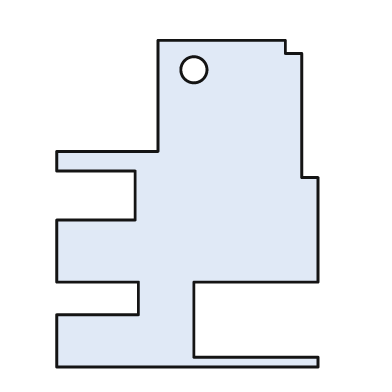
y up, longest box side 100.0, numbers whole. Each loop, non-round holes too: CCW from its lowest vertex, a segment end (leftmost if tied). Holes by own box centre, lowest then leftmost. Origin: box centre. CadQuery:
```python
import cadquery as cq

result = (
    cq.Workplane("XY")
    .moveTo(-40.0, -50.0)
    .lineTo(40.0, -50.0)
    .lineTo(40.0, -47.0)
    .lineTo(2.0, -47.0)
    .lineTo(2.0, -24.0)
    .lineTo(40.0, -24.0)
    .lineTo(40.0, 8.0)
    .lineTo(35.0, 8.0)
    .lineTo(35.0, 46.0)
    .lineTo(30.0, 46.0)
    .lineTo(30.0, 50.0)
    .lineTo(-9.0, 50.0)
    .lineTo(-9.0, 16.0)
    .lineTo(-40.0, 16.0)
    .lineTo(-40.0, 10.0)
    .lineTo(-16.0, 10.0)
    .lineTo(-16.0, -5.0)
    .lineTo(-40.0, -5.0)
    .lineTo(-40.0, -24.0)
    .lineTo(-15.0, -24.0)
    .lineTo(-15.0, -34.0)
    .lineTo(-40.0, -34.0)
    .close()
    .moveTo(2.0, 41.0)
    .circle(4.0)
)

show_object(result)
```